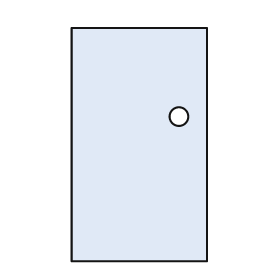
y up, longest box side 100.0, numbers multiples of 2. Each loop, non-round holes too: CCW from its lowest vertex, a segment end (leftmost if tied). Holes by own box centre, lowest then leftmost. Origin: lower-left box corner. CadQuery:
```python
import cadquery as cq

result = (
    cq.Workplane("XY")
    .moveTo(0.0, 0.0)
    .lineTo(58.0, 0.0)
    .lineTo(58.0, 100.0)
    .lineTo(0.0, 100.0)
    .close()
    .moveTo(46.0, 62.0)
    .circle(4.0)
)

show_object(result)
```